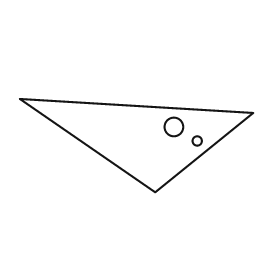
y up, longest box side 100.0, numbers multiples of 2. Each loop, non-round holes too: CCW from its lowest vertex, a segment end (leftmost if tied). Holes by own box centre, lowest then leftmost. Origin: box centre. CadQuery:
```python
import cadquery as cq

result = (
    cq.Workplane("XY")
    .moveTo(8.0, -20.0)
    .lineTo(50.0, 14.0)
    .lineTo(-50.0, 20.0)
    .close()
    .moveTo(26.0, 2.0)
    .circle(2.0)
    .moveTo(16.0, 8.0)
    .circle(4.0)
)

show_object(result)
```